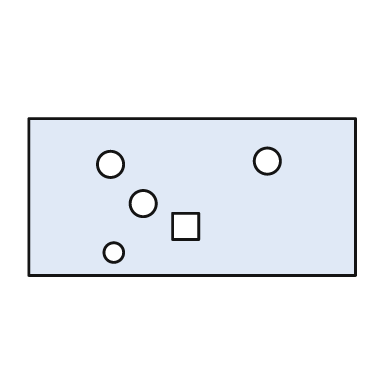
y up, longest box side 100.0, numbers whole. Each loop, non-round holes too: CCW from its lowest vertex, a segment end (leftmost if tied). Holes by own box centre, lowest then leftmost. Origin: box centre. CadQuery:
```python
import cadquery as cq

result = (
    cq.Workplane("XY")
    .moveTo(-50.0, -24.0)
    .lineTo(50.0, -24.0)
    .lineTo(50.0, 24.0)
    .lineTo(-50.0, 24.0)
    .close()
    .moveTo(-24.0, -17.0)
    .circle(3.0)
    .moveTo(-6.0, -13.0)
    .lineTo(2.0, -13.0)
    .lineTo(2.0, -5.0)
    .lineTo(-6.0, -5.0)
    .close()
    .moveTo(-15.0, -2.0)
    .circle(4.0)
    .moveTo(-25.0, 10.0)
    .circle(4.0)
    .moveTo(23.0, 11.0)
    .circle(4.0)
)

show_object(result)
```